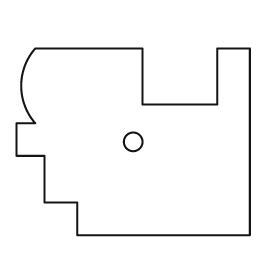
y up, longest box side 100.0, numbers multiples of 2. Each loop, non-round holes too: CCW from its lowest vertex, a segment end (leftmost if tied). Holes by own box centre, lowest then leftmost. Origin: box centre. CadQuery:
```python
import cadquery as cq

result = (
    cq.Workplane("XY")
    .moveTo(-24.0, -40.0)
    .lineTo(50.0, -40.0)
    .lineTo(50.0, 40.0)
    .lineTo(36.0, 40.0)
    .lineTo(36.0, 16.0)
    .lineTo(4.0, 16.0)
    .lineTo(4.0, 40.0)
    .lineTo(-42.0, 40.0)
    .threePointArc((-48.0, 24.0), (-42.0, 8.0))
    .lineTo(-50.0, 8.0)
    .lineTo(-50.0, -6.0)
    .lineTo(-38.0, -6.0)
    .lineTo(-38.0, -26.0)
    .lineTo(-24.0, -26.0)
    .close()
    .moveTo(0.0, 0.0)
    .circle(4.0)
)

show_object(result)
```